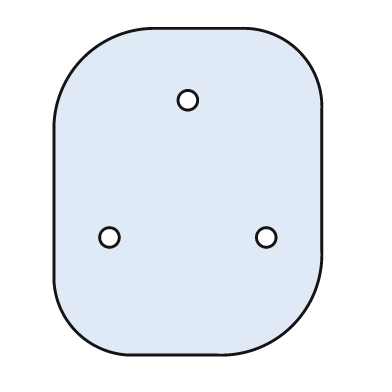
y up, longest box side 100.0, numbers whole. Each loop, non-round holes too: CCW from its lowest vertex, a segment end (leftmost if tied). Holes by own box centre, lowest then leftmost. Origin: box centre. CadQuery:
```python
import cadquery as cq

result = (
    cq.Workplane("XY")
    .moveTo(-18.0, -50.0)
    .lineTo(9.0, -50.0)
    .threePointArc((32.0, -41.0), (41.0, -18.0))
    .lineTo(41.0, 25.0)
    .threePointArc((34.0, 43.0), (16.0, 50.0))
    .lineTo(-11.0, 50.0)
    .threePointArc((-32.0, 41.0), (-41.0, 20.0))
    .lineTo(-41.0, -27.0)
    .threePointArc((-34.0, -43.0), (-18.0, -50.0))
    .close()
    .moveTo(-24.0, -14.0)
    .circle(3.0)
    .moveTo(24.0, -14.0)
    .circle(3.0)
    .moveTo(0.0, 28.0)
    .circle(3.0)
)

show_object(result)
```